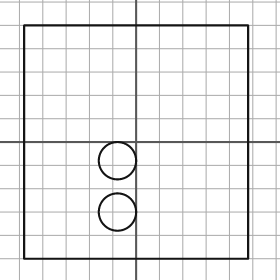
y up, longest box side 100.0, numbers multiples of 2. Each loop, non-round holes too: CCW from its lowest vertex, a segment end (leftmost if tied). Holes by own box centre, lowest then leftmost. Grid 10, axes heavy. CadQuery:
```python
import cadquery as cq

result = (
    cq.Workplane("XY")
    .moveTo(-48.0, -50.0)
    .lineTo(48.0, -50.0)
    .lineTo(48.0, 50.0)
    .lineTo(-48.0, 50.0)
    .close()
    .moveTo(-8.0, -30.0)
    .circle(8.0)
    .moveTo(-8.0, -8.0)
    .circle(8.0)
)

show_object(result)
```